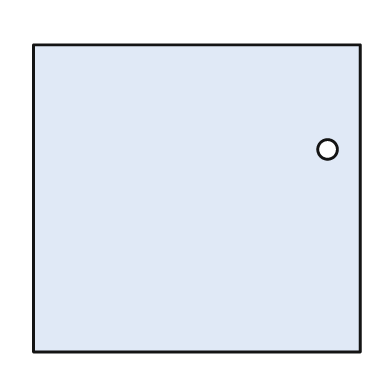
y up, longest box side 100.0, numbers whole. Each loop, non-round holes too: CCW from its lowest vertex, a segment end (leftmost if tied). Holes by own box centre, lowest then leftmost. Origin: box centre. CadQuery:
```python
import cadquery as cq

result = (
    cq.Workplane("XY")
    .moveTo(-50.0, -47.0)
    .lineTo(50.0, -47.0)
    .lineTo(50.0, 47.0)
    .lineTo(-50.0, 47.0)
    .close()
    .moveTo(40.0, 15.0)
    .circle(3.0)
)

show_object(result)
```